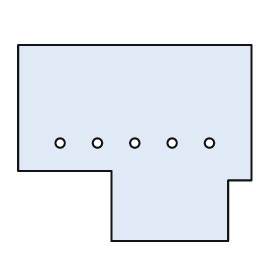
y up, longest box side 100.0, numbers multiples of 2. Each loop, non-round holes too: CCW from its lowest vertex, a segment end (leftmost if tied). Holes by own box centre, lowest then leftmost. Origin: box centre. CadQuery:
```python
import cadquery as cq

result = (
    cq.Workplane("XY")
    .moveTo(-10.0, -42.0)
    .lineTo(40.0, -42.0)
    .lineTo(40.0, -16.0)
    .lineTo(50.0, -16.0)
    .lineTo(50.0, 42.0)
    .lineTo(-50.0, 42.0)
    .lineTo(-50.0, -12.0)
    .lineTo(-10.0, -12.0)
    .close()
    .moveTo(-32.0, 0.0)
    .circle(2.0)
    .moveTo(-16.0, 0.0)
    .circle(2.0)
    .moveTo(0.0, 0.0)
    .circle(2.0)
    .moveTo(16.0, 0.0)
    .circle(2.0)
    .moveTo(32.0, 0.0)
    .circle(2.0)
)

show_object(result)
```